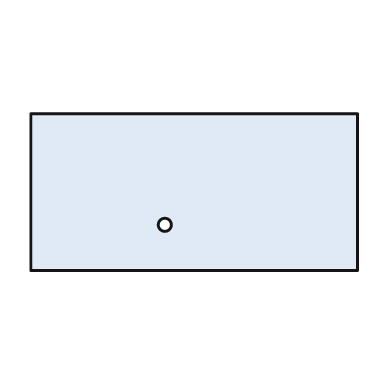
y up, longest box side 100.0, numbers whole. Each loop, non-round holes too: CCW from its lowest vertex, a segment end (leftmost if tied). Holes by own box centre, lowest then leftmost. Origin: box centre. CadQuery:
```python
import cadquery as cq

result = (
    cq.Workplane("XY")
    .moveTo(-50.0, -24.0)
    .lineTo(50.0, -24.0)
    .lineTo(50.0, 24.0)
    .lineTo(-50.0, 24.0)
    .close()
    .moveTo(-9.0, -10.0)
    .circle(2.0)
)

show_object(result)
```